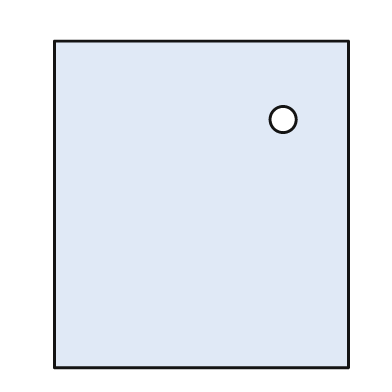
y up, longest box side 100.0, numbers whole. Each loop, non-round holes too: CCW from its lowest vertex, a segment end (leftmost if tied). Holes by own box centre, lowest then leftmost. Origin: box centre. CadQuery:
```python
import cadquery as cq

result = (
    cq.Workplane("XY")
    .moveTo(-45.0, -50.0)
    .lineTo(45.0, -50.0)
    .lineTo(45.0, 50.0)
    .lineTo(-45.0, 50.0)
    .close()
    .moveTo(25.0, 26.0)
    .circle(4.0)
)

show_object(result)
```